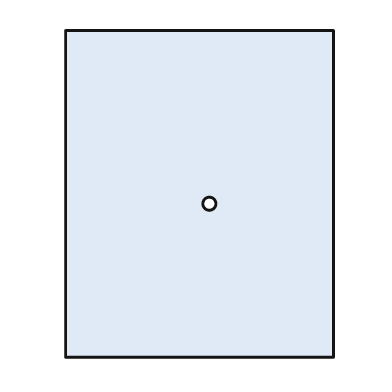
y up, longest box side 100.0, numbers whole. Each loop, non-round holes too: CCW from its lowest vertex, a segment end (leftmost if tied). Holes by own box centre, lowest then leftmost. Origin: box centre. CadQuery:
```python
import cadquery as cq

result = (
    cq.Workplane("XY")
    .moveTo(-41.0, -50.0)
    .lineTo(41.0, -50.0)
    .lineTo(41.0, 50.0)
    .lineTo(-41.0, 50.0)
    .close()
    .moveTo(3.0, -3.0)
    .circle(2.0)
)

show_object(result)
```